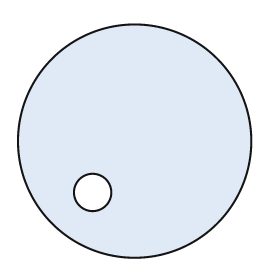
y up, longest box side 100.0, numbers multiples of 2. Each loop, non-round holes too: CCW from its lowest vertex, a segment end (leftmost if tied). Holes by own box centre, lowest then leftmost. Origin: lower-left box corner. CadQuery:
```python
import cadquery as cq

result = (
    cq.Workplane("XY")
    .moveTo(50.0, 50.0)
    .circle(50.0)
    .moveTo(32.0, 28.0)
    .circle(8.0)
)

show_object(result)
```